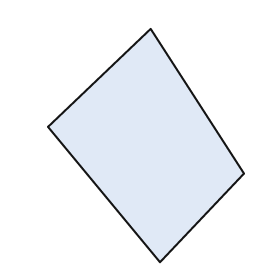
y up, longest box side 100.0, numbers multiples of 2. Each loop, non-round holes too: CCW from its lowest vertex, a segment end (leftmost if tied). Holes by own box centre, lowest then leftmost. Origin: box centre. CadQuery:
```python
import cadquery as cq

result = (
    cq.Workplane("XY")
    .moveTo(6.0, -50.0)
    .lineTo(42.0, -12.0)
    .lineTo(2.0, 50.0)
    .lineTo(-42.0, 8.0)
    .close()
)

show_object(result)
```